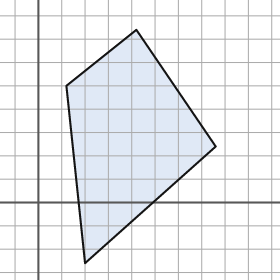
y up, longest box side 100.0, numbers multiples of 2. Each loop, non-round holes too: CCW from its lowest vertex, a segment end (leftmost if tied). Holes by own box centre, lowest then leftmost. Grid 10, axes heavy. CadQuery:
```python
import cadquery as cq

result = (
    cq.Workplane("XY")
    .moveTo(20.0, -26.0)
    .lineTo(76.0, 24.0)
    .lineTo(42.0, 74.0)
    .lineTo(12.0, 50.0)
    .close()
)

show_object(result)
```